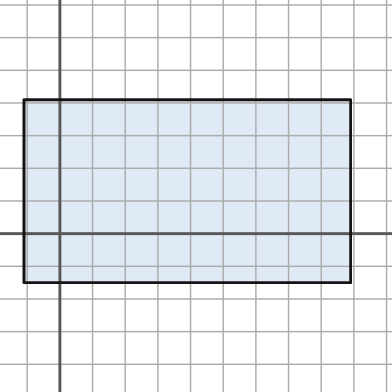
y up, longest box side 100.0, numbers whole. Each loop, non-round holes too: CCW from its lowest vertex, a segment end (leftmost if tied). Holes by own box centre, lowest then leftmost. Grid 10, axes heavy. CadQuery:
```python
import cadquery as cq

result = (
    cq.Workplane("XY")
    .moveTo(-11.0, -15.0)
    .lineTo(89.0, -15.0)
    .lineTo(89.0, 41.0)
    .lineTo(-11.0, 41.0)
    .close()
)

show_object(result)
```